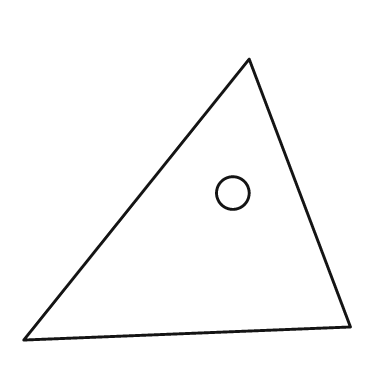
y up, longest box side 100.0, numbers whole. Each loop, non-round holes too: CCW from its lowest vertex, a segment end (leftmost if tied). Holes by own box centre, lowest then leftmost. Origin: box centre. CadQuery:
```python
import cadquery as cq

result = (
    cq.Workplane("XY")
    .moveTo(-50.0, -43.0)
    .lineTo(50.0, -39.0)
    .lineTo(19.0, 43.0)
    .close()
    .moveTo(14.0, 2.0)
    .circle(5.0)
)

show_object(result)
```